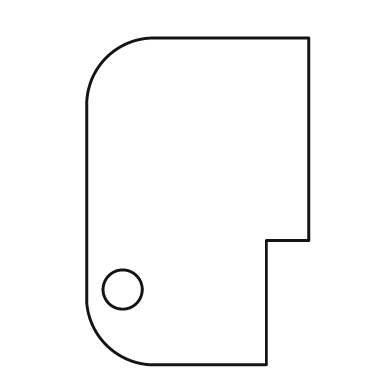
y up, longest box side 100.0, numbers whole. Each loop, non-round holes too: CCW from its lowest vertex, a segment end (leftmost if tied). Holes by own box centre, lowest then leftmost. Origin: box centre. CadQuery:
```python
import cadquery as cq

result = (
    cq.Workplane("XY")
    .moveTo(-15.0, -50.0)
    .lineTo(21.0, -50.0)
    .lineTo(21.0, -12.0)
    .lineTo(34.0, -12.0)
    .lineTo(34.0, 50.0)
    .lineTo(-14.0, 50.0)
    .threePointArc((-28.0, 44.0), (-34.0, 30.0))
    .lineTo(-34.0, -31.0)
    .threePointArc((-28.0, -44.0), (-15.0, -50.0))
    .close()
    .moveTo(-23.0, -27.0)
    .circle(6.0)
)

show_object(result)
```